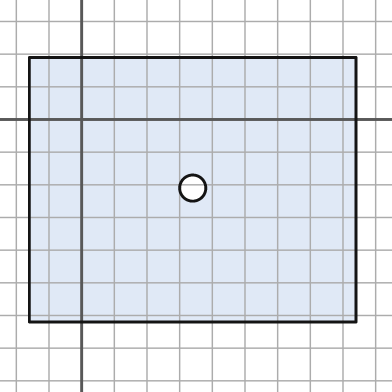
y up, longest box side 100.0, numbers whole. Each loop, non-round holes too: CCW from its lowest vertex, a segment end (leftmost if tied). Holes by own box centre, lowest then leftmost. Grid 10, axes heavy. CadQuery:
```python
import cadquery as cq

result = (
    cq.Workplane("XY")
    .moveTo(-16.0, -62.0)
    .lineTo(84.0, -62.0)
    .lineTo(84.0, 19.0)
    .lineTo(-16.0, 19.0)
    .close()
    .moveTo(34.0, -21.0)
    .circle(4.0)
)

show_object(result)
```